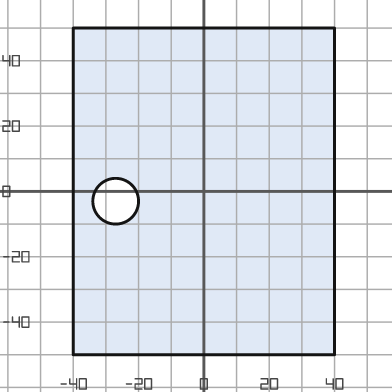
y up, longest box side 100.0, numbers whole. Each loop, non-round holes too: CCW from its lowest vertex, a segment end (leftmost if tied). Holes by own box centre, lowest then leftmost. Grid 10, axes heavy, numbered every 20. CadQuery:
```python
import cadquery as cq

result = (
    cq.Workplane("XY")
    .moveTo(-40.0, -50.0)
    .lineTo(40.0, -50.0)
    .lineTo(40.0, 50.0)
    .lineTo(-40.0, 50.0)
    .close()
    .moveTo(-27.0, -3.0)
    .circle(7.0)
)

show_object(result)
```